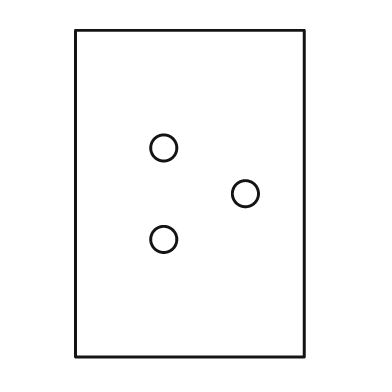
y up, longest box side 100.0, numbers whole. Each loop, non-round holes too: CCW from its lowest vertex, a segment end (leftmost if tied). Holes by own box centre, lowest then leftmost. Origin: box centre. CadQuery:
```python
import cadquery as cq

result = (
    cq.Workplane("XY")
    .moveTo(-35.0, -50.0)
    .lineTo(35.0, -50.0)
    .lineTo(35.0, 50.0)
    .lineTo(-35.0, 50.0)
    .close()
    .moveTo(-8.0, -14.0)
    .circle(4.0)
    .moveTo(17.0, 0.0)
    .circle(4.0)
    .moveTo(-8.0, 14.0)
    .circle(4.0)
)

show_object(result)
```